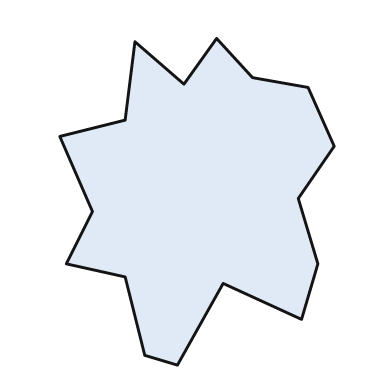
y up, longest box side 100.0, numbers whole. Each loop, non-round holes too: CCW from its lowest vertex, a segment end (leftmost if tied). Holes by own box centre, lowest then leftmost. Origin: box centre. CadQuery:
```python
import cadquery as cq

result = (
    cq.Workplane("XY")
    .moveTo(-6.0, -50.0)
    .lineTo(8.0, -25.0)
    .lineTo(32.0, -36.0)
    .lineTo(37.0, -19.0)
    .lineTo(31.0, 1.0)
    .lineTo(42.0, 17.0)
    .lineTo(34.0, 35.0)
    .lineTo(17.0, 38.0)
    .lineTo(6.0, 50.0)
    .lineTo(-4.0, 36.0)
    .lineTo(-19.0, 49.0)
    .lineTo(-22.0, 25.0)
    .lineTo(-42.0, 20.0)
    .lineTo(-32.0, -3.0)
    .lineTo(-40.0, -19.0)
    .lineTo(-22.0, -23.0)
    .lineTo(-16.0, -47.0)
    .close()
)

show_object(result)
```